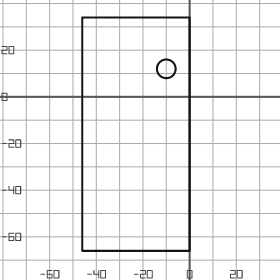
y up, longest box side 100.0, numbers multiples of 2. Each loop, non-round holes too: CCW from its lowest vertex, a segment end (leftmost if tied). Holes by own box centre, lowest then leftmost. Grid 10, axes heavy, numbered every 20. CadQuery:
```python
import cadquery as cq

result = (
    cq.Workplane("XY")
    .moveTo(-46.0, -66.0)
    .lineTo(0.0, -66.0)
    .lineTo(0.0, 34.0)
    .lineTo(-46.0, 34.0)
    .close()
    .moveTo(-10.0, 12.0)
    .circle(4.0)
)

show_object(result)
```